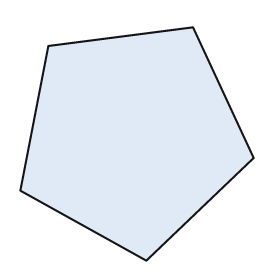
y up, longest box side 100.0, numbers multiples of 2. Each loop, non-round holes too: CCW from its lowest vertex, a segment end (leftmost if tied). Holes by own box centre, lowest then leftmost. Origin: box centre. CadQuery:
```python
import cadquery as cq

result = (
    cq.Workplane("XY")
    .moveTo(4.0, -50.0)
    .lineTo(50.0, -6.0)
    .lineTo(24.0, 50.0)
    .lineTo(-38.0, 42.0)
    .lineTo(-50.0, -20.0)
    .close()
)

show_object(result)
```